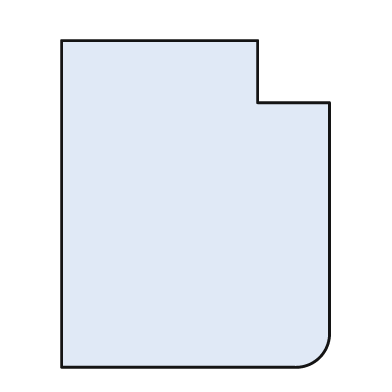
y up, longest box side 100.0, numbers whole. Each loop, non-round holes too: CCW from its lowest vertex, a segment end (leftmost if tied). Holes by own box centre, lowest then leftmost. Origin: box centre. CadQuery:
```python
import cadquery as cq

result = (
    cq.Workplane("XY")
    .moveTo(-41.0, -50.0)
    .lineTo(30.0, -50.0)
    .threePointArc((38.0, -47.0), (41.0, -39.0))
    .lineTo(41.0, 31.0)
    .lineTo(19.0, 31.0)
    .lineTo(19.0, 50.0)
    .lineTo(-41.0, 50.0)
    .close()
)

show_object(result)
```